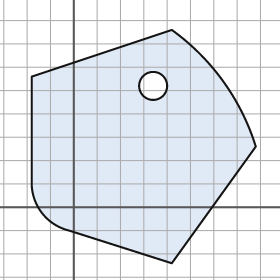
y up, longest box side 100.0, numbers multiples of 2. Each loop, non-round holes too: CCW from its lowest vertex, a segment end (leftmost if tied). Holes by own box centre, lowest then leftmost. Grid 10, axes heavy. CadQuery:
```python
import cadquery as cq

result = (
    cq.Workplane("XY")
    .moveTo(42.0, -24.0)
    .lineTo(78.0, 26.0)
    .threePointArc((64.0, 54.0), (42.0, 76.0))
    .lineTo(-18.0, 56.0)
    .lineTo(-18.0, 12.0)
    .threePointArc((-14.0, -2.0), (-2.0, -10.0))
    .close()
    .moveTo(34.0, 52.0)
    .circle(6.0)
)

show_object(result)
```